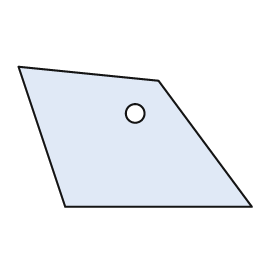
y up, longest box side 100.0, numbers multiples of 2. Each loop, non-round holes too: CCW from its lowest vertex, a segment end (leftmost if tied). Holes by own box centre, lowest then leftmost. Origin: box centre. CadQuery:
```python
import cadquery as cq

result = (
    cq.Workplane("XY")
    .moveTo(-30.0, -30.0)
    .lineTo(50.0, -30.0)
    .lineTo(10.0, 24.0)
    .lineTo(-50.0, 30.0)
    .close()
    .moveTo(0.0, 10.0)
    .circle(4.0)
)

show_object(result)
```